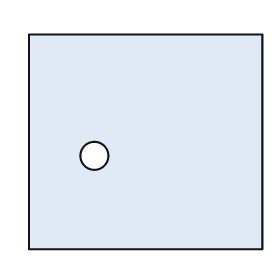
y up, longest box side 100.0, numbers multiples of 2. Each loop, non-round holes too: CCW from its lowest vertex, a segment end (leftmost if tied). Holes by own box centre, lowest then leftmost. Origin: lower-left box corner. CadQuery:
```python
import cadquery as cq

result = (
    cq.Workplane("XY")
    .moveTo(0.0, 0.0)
    .lineTo(100.0, 0.0)
    .lineTo(100.0, 92.0)
    .lineTo(0.0, 92.0)
    .close()
    .moveTo(28.0, 40.0)
    .circle(6.0)
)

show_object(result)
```